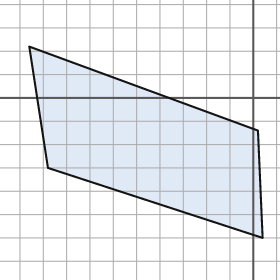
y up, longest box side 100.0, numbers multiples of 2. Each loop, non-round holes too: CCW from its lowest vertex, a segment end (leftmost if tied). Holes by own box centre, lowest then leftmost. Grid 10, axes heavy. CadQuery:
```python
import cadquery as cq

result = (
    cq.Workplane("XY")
    .moveTo(4.0, -60.0)
    .lineTo(2.0, -14.0)
    .lineTo(-96.0, 22.0)
    .lineTo(-88.0, -30.0)
    .close()
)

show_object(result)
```